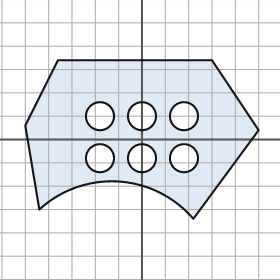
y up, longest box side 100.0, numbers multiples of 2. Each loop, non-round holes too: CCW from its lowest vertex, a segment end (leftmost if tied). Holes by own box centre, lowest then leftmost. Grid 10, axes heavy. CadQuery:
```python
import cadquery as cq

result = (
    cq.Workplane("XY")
    .moveTo(22.0, -34.0)
    .lineTo(50.0, 4.0)
    .lineTo(30.0, 34.0)
    .lineTo(-36.0, 34.0)
    .lineTo(-50.0, 6.0)
    .lineTo(-44.0, -30.0)
    .threePointArc((-10.0, -18.0), (22.0, -34.0))
    .close()
    .moveTo(-18.0, -8.0)
    .circle(6.0)
    .moveTo(0.0, -8.0)
    .circle(6.0)
    .moveTo(18.0, -8.0)
    .circle(6.0)
    .moveTo(-18.0, 10.0)
    .circle(6.0)
    .moveTo(0.0, 10.0)
    .circle(6.0)
    .moveTo(18.0, 10.0)
    .circle(6.0)
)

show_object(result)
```